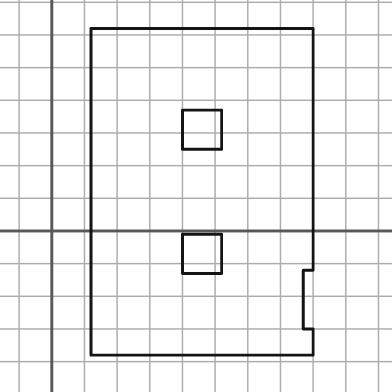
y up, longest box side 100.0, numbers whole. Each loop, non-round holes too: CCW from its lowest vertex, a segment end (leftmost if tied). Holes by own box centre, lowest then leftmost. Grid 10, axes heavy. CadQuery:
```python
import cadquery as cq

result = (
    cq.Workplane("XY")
    .moveTo(12.0, -38.0)
    .lineTo(80.0, -38.0)
    .lineTo(80.0, -30.0)
    .lineTo(77.0, -30.0)
    .lineTo(77.0, -12.0)
    .lineTo(80.0, -12.0)
    .lineTo(80.0, 62.0)
    .lineTo(12.0, 62.0)
    .close()
    .moveTo(40.0, -13.0)
    .lineTo(52.0, -13.0)
    .lineTo(52.0, -1.0)
    .lineTo(40.0, -1.0)
    .close()
    .moveTo(40.0, 25.0)
    .lineTo(52.0, 25.0)
    .lineTo(52.0, 37.0)
    .lineTo(40.0, 37.0)
    .close()
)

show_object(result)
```